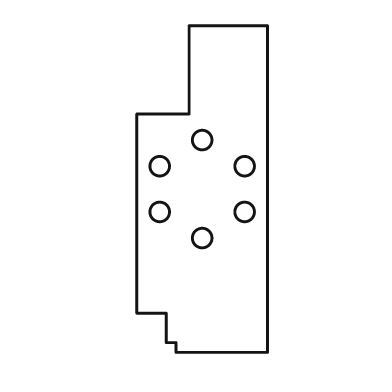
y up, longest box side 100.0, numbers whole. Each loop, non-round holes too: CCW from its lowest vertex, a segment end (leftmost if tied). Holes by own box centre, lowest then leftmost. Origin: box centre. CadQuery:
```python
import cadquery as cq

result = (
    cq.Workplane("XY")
    .moveTo(-8.0, -50.0)
    .lineTo(20.0, -50.0)
    .lineTo(20.0, 50.0)
    .lineTo(-4.0, 50.0)
    .lineTo(-4.0, 23.0)
    .lineTo(-20.0, 23.0)
    .lineTo(-20.0, -38.0)
    .lineTo(-11.0, -38.0)
    .lineTo(-11.0, -47.0)
    .lineTo(-8.0, -47.0)
    .close()
    .moveTo(0.0, -15.0)
    .circle(3.0)
    .moveTo(-13.0, -7.0)
    .circle(3.0)
    .moveTo(13.0, -7.0)
    .circle(3.0)
    .moveTo(-13.0, 7.0)
    .circle(3.0)
    .moveTo(13.0, 7.0)
    .circle(3.0)
    .moveTo(0.0, 15.0)
    .circle(3.0)
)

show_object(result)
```